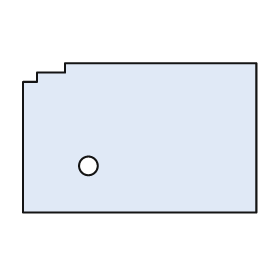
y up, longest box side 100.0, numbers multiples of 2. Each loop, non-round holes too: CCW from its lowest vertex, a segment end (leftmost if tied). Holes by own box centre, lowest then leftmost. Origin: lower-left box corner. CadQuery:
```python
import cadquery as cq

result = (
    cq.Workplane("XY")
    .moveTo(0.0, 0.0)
    .lineTo(100.0, 0.0)
    .lineTo(100.0, 64.0)
    .lineTo(18.0, 64.0)
    .lineTo(18.0, 60.0)
    .lineTo(6.0, 60.0)
    .lineTo(6.0, 56.0)
    .lineTo(0.0, 56.0)
    .close()
    .moveTo(28.0, 20.0)
    .circle(4.0)
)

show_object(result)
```